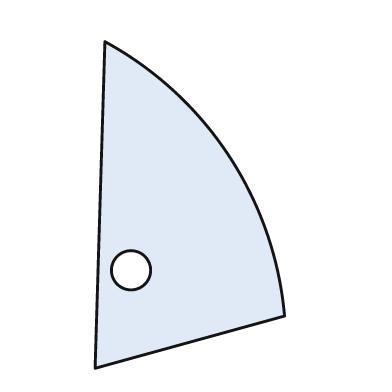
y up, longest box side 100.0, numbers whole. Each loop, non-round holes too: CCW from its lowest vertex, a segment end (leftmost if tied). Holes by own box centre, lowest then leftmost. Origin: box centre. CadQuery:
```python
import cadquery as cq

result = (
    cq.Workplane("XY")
    .moveTo(-29.0, -50.0)
    .lineTo(29.0, -34.0)
    .threePointArc((12.0, 15.0), (-26.0, 50.0))
    .close()
    .moveTo(-18.0, -20.0)
    .circle(6.0)
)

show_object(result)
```